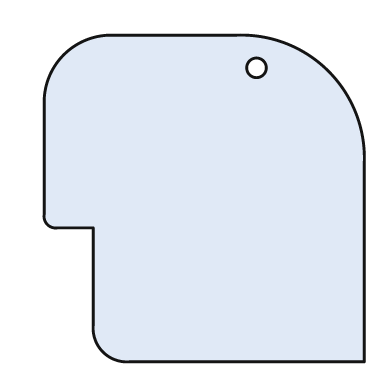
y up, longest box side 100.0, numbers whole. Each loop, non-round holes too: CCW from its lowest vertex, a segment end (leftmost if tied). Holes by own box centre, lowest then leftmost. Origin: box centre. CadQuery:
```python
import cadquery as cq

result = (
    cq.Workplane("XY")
    .moveTo(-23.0, -50.0)
    .lineTo(49.0, -50.0)
    .lineTo(49.0, 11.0)
    .threePointArc((38.0, 39.0), (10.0, 50.0))
    .lineTo(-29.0, 50.0)
    .threePointArc((-43.0, 44.0), (-49.0, 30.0))
    .lineTo(-49.0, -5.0)
    .threePointArc((-48.0, -8.0), (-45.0, -9.0))
    .lineTo(-34.0, -9.0)
    .lineTo(-34.0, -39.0)
    .threePointArc((-31.0, -47.0), (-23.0, -50.0))
    .close()
    .moveTo(16.0, 40.0)
    .circle(3.0)
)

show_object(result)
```